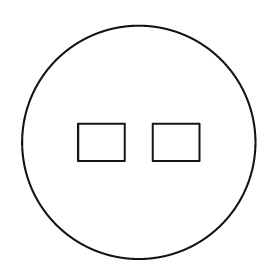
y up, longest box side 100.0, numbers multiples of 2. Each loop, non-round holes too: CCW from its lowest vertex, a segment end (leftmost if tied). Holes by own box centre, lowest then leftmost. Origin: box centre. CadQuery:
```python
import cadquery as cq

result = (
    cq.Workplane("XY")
    .moveTo(0.0, 0.0)
    .circle(50.0)
    .moveTo(-26.0, -8.0)
    .lineTo(-6.0, -8.0)
    .lineTo(-6.0, 8.0)
    .lineTo(-26.0, 8.0)
    .close()
    .moveTo(6.0, -8.0)
    .lineTo(26.0, -8.0)
    .lineTo(26.0, 8.0)
    .lineTo(6.0, 8.0)
    .close()
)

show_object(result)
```